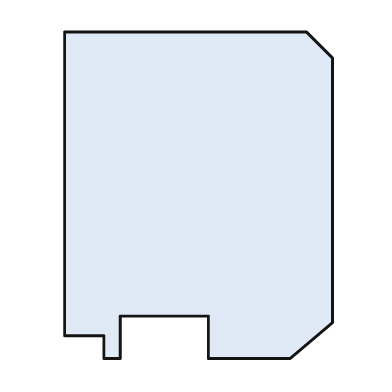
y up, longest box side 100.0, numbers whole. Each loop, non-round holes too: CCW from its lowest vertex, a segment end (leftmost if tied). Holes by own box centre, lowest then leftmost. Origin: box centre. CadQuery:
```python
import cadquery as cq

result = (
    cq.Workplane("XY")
    .moveTo(-29.0, -50.0)
    .lineTo(-24.0, -50.0)
    .lineTo(-24.0, -37.0)
    .lineTo(3.0, -37.0)
    .lineTo(3.0, -50.0)
    .lineTo(28.0, -50.0)
    .lineTo(41.0, -39.0)
    .lineTo(41.0, 42.0)
    .lineTo(33.0, 50.0)
    .lineTo(-41.0, 50.0)
    .lineTo(-41.0, -43.0)
    .lineTo(-29.0, -43.0)
    .close()
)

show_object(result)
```